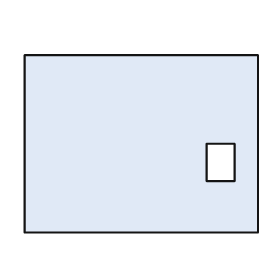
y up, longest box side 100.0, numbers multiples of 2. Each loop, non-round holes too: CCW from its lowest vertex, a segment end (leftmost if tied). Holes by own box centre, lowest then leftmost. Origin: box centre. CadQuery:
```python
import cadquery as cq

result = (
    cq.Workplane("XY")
    .moveTo(-50.0, -38.0)
    .lineTo(50.0, -38.0)
    .lineTo(50.0, 38.0)
    .lineTo(-50.0, 38.0)
    .close()
    .moveTo(28.0, -16.0)
    .lineTo(40.0, -16.0)
    .lineTo(40.0, 0.0)
    .lineTo(28.0, 0.0)
    .close()
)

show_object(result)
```